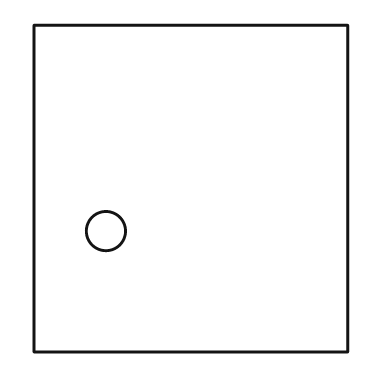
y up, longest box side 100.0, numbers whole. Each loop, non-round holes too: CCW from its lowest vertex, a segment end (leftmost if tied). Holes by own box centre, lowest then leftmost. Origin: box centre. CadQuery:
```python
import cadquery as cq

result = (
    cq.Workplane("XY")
    .moveTo(-48.0, -50.0)
    .lineTo(48.0, -50.0)
    .lineTo(48.0, 50.0)
    .lineTo(-48.0, 50.0)
    .close()
    .moveTo(-26.0, -13.0)
    .circle(6.0)
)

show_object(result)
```